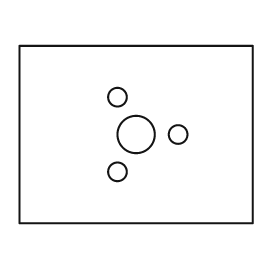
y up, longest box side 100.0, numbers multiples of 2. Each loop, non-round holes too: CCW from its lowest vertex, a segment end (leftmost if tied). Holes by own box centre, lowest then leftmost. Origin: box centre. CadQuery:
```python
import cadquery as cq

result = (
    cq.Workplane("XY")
    .moveTo(-50.0, -38.0)
    .lineTo(50.0, -38.0)
    .lineTo(50.0, 38.0)
    .lineTo(-50.0, 38.0)
    .close()
    .moveTo(-8.0, -16.0)
    .circle(4.0)
    .moveTo(0.0, 0.0)
    .circle(8.0)
    .moveTo(18.0, 0.0)
    .circle(4.0)
    .moveTo(-8.0, 16.0)
    .circle(4.0)
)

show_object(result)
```